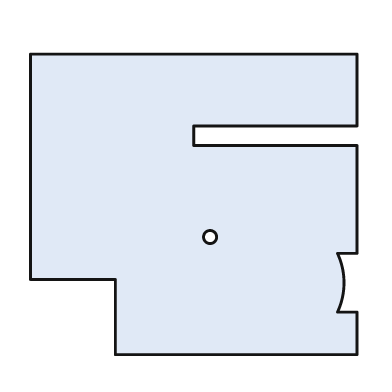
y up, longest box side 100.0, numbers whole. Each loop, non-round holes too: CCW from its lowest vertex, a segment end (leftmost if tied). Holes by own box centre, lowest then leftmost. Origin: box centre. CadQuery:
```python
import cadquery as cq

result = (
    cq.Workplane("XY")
    .moveTo(-24.0, -46.0)
    .lineTo(50.0, -46.0)
    .lineTo(50.0, -33.0)
    .lineTo(44.0, -33.0)
    .threePointArc((46.0, -24.0), (44.0, -15.0))
    .lineTo(50.0, -15.0)
    .lineTo(50.0, 18.0)
    .lineTo(0.0, 18.0)
    .lineTo(0.0, 24.0)
    .lineTo(50.0, 24.0)
    .lineTo(50.0, 46.0)
    .lineTo(-50.0, 46.0)
    .lineTo(-50.0, -23.0)
    .lineTo(-24.0, -23.0)
    .close()
    .moveTo(5.0, -10.0)
    .circle(2.0)
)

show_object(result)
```